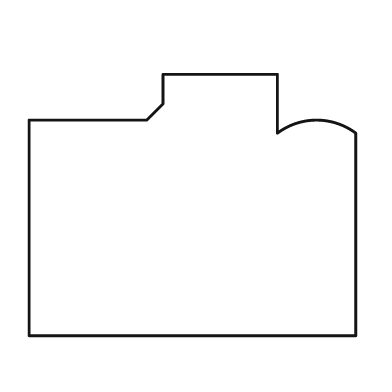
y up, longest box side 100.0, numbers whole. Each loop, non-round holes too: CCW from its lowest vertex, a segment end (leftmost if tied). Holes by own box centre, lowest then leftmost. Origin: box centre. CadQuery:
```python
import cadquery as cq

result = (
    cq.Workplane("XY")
    .moveTo(-50.0, -40.0)
    .lineTo(50.0, -40.0)
    .lineTo(50.0, 22.0)
    .threePointArc((38.0, 26.0), (26.0, 22.0))
    .lineTo(26.0, 40.0)
    .lineTo(-9.0, 40.0)
    .lineTo(-9.0, 31.0)
    .lineTo(-14.0, 26.0)
    .lineTo(-50.0, 26.0)
    .close()
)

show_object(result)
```